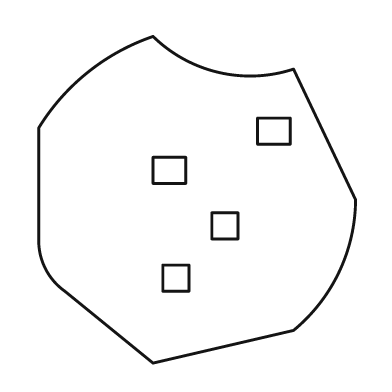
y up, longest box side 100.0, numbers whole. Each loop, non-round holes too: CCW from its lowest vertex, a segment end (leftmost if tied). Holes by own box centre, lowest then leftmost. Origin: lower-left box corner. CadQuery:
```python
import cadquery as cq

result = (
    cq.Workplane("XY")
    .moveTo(35.0, 0.0)
    .lineTo(78.0, 10.0)
    .threePointArc((92.0, 28.0), (97.0, 50.0))
    .lineTo(78.0, 90.0)
    .threePointArc((55.0, 89.0), (35.0, 100.0))
    .threePointArc((15.0, 89.0), (0.0, 72.0))
    .lineTo(0.0, 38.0)
    .threePointArc((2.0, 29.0), (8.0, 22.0))
    .close()
    .moveTo(38.0, 22.0)
    .lineTo(46.0, 22.0)
    .lineTo(46.0, 30.0)
    .lineTo(38.0, 30.0)
    .close()
    .moveTo(53.0, 38.0)
    .lineTo(61.0, 38.0)
    .lineTo(61.0, 46.0)
    .lineTo(53.0, 46.0)
    .close()
    .moveTo(35.0, 55.0)
    .lineTo(45.0, 55.0)
    .lineTo(45.0, 63.0)
    .lineTo(35.0, 63.0)
    .close()
    .moveTo(67.0, 67.0)
    .lineTo(77.0, 67.0)
    .lineTo(77.0, 75.0)
    .lineTo(67.0, 75.0)
    .close()
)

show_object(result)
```